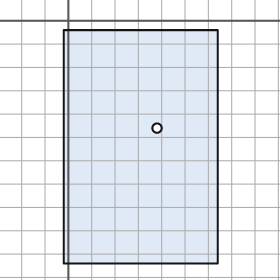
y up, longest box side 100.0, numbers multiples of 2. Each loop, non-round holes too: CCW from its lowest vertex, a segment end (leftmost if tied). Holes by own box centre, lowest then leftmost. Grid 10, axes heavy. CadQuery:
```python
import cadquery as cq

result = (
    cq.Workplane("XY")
    .moveTo(-2.0, -104.0)
    .lineTo(64.0, -104.0)
    .lineTo(64.0, -4.0)
    .lineTo(-2.0, -4.0)
    .close()
    .moveTo(38.0, -46.0)
    .circle(2.0)
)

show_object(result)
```